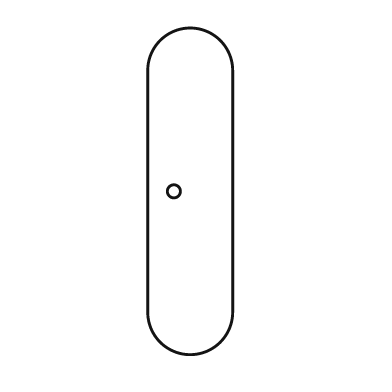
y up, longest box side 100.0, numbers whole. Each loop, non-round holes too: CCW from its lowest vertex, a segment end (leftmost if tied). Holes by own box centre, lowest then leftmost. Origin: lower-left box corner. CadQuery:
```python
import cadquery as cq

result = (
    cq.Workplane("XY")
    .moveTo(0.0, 13.0)
    .threePointArc((13.0, 0.0), (26.0, 13.0))
    .lineTo(26.0, 87.0)
    .threePointArc((13.0, 100.0), (0.0, 87.0))
    .close()
    .moveTo(8.0, 50.0)
    .circle(2.0)
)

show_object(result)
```